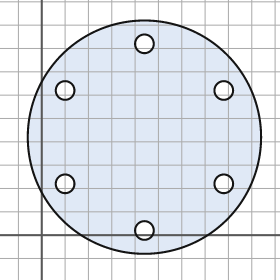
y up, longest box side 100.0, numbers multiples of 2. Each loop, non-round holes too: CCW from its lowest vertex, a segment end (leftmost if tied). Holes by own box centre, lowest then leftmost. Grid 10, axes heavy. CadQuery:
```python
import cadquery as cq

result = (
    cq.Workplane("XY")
    .moveTo(44.0, 42.0)
    .circle(50.0)
    .moveTo(44.0, 2.0)
    .circle(4.0)
    .moveTo(10.0, 22.0)
    .circle(4.0)
    .moveTo(78.0, 22.0)
    .circle(4.0)
    .moveTo(10.0, 62.0)
    .circle(4.0)
    .moveTo(78.0, 62.0)
    .circle(4.0)
    .moveTo(44.0, 82.0)
    .circle(4.0)
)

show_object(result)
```